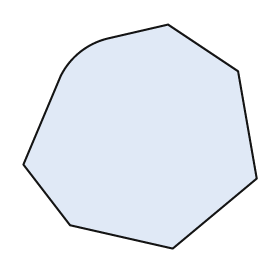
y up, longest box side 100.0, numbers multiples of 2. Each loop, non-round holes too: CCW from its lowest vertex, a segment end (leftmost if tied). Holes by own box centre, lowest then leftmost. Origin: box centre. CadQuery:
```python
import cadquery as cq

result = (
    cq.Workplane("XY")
    .moveTo(14.0, -48.0)
    .lineTo(50.0, -18.0)
    .lineTo(42.0, 28.0)
    .lineTo(12.0, 48.0)
    .lineTo(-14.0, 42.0)
    .threePointArc((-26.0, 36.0), (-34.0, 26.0))
    .lineTo(-50.0, -12.0)
    .lineTo(-30.0, -38.0)
    .close()
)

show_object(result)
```